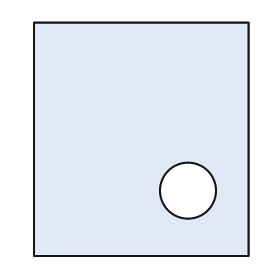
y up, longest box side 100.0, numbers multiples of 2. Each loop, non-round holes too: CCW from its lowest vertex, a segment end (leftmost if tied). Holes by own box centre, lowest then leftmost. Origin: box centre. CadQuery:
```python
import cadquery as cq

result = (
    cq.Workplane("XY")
    .moveTo(-46.0, -50.0)
    .lineTo(46.0, -50.0)
    .lineTo(46.0, 50.0)
    .lineTo(-46.0, 50.0)
    .close()
    .moveTo(20.0, -22.0)
    .circle(12.0)
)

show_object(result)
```